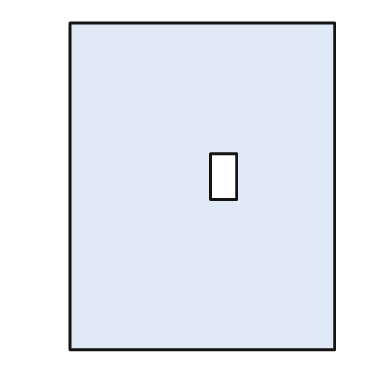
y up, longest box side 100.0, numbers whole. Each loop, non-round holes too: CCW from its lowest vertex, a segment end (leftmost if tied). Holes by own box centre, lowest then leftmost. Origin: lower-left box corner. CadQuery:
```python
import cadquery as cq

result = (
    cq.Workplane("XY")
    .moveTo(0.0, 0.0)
    .lineTo(81.0, 0.0)
    .lineTo(81.0, 100.0)
    .lineTo(0.0, 100.0)
    .close()
    .moveTo(43.0, 46.0)
    .lineTo(51.0, 46.0)
    .lineTo(51.0, 60.0)
    .lineTo(43.0, 60.0)
    .close()
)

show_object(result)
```